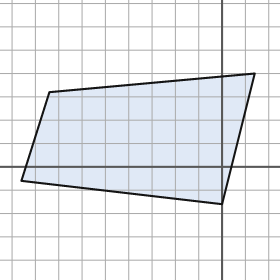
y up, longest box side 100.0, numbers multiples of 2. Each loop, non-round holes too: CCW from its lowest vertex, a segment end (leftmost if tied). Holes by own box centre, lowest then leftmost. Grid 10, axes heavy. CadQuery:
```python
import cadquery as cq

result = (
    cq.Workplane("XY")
    .moveTo(0.0, -16.0)
    .lineTo(14.0, 40.0)
    .lineTo(-74.0, 32.0)
    .lineTo(-86.0, -6.0)
    .close()
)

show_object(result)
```